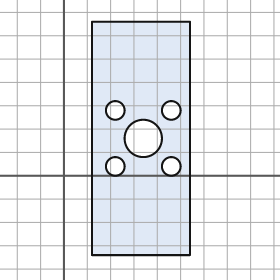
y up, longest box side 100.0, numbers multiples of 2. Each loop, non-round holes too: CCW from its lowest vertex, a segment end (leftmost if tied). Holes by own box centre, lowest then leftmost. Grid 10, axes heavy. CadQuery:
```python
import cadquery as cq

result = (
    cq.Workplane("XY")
    .moveTo(12.0, -34.0)
    .lineTo(54.0, -34.0)
    .lineTo(54.0, 66.0)
    .lineTo(12.0, 66.0)
    .close()
    .moveTo(22.0, 4.0)
    .circle(4.0)
    .moveTo(46.0, 4.0)
    .circle(4.0)
    .moveTo(34.0, 16.0)
    .circle(8.0)
    .moveTo(22.0, 28.0)
    .circle(4.0)
    .moveTo(46.0, 28.0)
    .circle(4.0)
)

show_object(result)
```